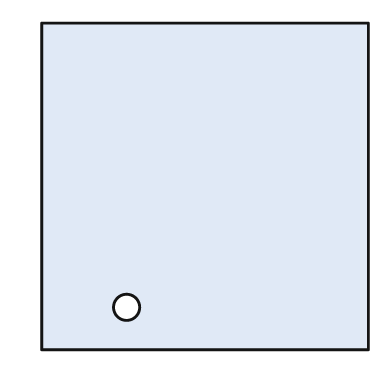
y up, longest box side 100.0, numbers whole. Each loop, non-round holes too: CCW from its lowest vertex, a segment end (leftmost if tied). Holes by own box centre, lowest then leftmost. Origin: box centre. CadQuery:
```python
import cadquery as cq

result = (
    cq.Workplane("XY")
    .moveTo(-50.0, -50.0)
    .lineTo(50.0, -50.0)
    .lineTo(50.0, 50.0)
    .lineTo(-50.0, 50.0)
    .close()
    .moveTo(-24.0, -37.0)
    .circle(4.0)
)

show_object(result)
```